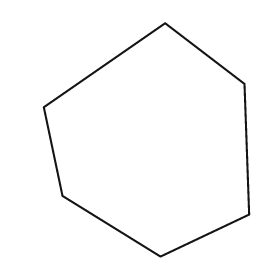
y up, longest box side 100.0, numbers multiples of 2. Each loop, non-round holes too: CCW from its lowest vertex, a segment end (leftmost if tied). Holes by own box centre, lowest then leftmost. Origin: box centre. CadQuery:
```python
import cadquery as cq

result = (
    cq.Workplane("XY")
    .moveTo(6.0, -50.0)
    .lineTo(44.0, -32.0)
    .lineTo(42.0, 24.0)
    .lineTo(8.0, 50.0)
    .lineTo(-44.0, 14.0)
    .lineTo(-36.0, -24.0)
    .close()
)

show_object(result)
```